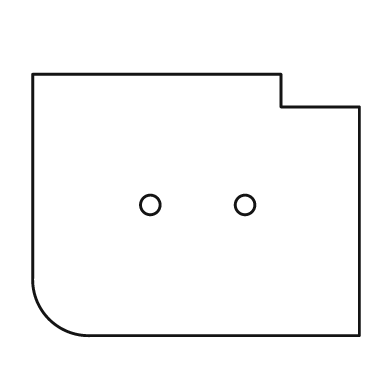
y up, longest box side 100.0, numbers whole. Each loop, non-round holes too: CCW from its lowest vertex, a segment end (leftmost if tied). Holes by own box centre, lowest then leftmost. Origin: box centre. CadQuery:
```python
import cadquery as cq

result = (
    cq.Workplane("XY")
    .moveTo(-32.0, -40.0)
    .lineTo(50.0, -40.0)
    .lineTo(50.0, 30.0)
    .lineTo(26.0, 30.0)
    .lineTo(26.0, 40.0)
    .lineTo(-50.0, 40.0)
    .lineTo(-50.0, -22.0)
    .threePointArc((-45.0, -35.0), (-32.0, -40.0))
    .close()
    .moveTo(-14.0, 0.0)
    .circle(3.0)
    .moveTo(15.0, 0.0)
    .circle(3.0)
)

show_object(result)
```